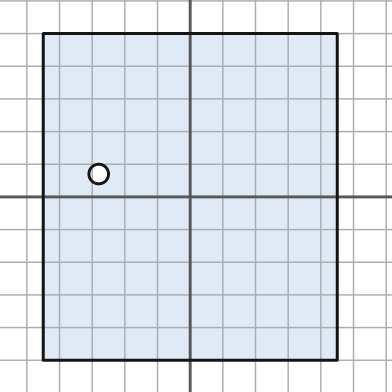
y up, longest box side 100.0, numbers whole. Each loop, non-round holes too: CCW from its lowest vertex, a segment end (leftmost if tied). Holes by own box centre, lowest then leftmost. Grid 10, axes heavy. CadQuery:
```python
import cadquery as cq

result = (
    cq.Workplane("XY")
    .moveTo(-45.0, -50.0)
    .lineTo(45.0, -50.0)
    .lineTo(45.0, 50.0)
    .lineTo(-45.0, 50.0)
    .close()
    .moveTo(-28.0, 7.0)
    .circle(3.0)
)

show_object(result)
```